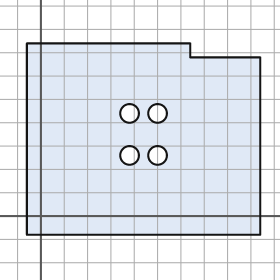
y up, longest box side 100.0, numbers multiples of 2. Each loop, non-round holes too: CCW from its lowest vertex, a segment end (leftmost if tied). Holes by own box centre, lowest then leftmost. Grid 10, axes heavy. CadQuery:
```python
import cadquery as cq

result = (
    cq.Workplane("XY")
    .moveTo(-6.0, -8.0)
    .lineTo(94.0, -8.0)
    .lineTo(94.0, 68.0)
    .lineTo(64.0, 68.0)
    .lineTo(64.0, 74.0)
    .lineTo(-6.0, 74.0)
    .close()
    .moveTo(38.0, 26.0)
    .circle(4.0)
    .moveTo(50.0, 26.0)
    .circle(4.0)
    .moveTo(38.0, 44.0)
    .circle(4.0)
    .moveTo(50.0, 44.0)
    .circle(4.0)
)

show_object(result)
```